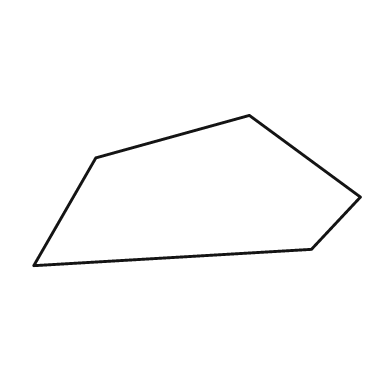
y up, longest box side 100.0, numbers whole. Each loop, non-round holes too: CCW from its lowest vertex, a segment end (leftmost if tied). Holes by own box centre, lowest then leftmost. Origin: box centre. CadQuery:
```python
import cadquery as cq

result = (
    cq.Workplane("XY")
    .moveTo(-50.0, -23.0)
    .lineTo(35.0, -18.0)
    .lineTo(50.0, -2.0)
    .lineTo(16.0, 23.0)
    .lineTo(-31.0, 10.0)
    .close()
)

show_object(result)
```